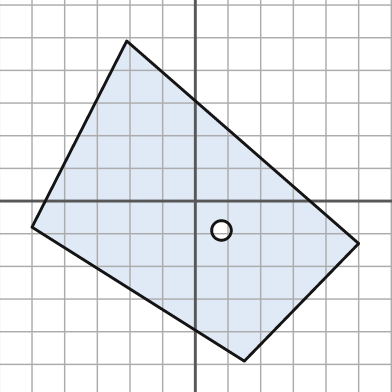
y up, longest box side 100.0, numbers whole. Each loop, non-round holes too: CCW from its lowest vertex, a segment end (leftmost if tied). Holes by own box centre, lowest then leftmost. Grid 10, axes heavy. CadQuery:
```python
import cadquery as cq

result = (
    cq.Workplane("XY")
    .moveTo(15.0, -49.0)
    .lineTo(50.0, -13.0)
    .lineTo(-21.0, 49.0)
    .lineTo(-50.0, -8.0)
    .close()
    .moveTo(8.0, -9.0)
    .circle(3.0)
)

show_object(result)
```